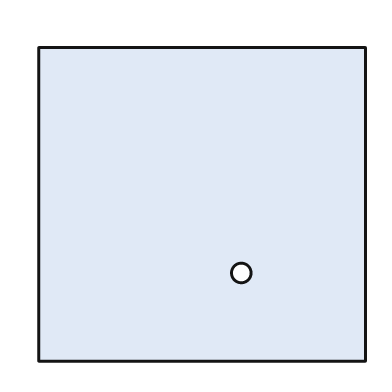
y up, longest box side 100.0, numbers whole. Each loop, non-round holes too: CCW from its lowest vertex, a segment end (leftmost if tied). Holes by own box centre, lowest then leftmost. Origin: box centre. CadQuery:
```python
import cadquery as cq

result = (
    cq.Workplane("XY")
    .moveTo(-50.0, -48.0)
    .lineTo(50.0, -48.0)
    .lineTo(50.0, 48.0)
    .lineTo(-50.0, 48.0)
    .close()
    .moveTo(12.0, -21.0)
    .circle(3.0)
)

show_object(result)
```